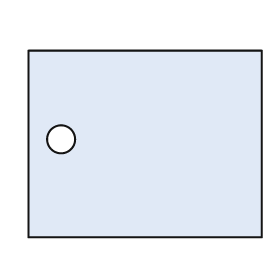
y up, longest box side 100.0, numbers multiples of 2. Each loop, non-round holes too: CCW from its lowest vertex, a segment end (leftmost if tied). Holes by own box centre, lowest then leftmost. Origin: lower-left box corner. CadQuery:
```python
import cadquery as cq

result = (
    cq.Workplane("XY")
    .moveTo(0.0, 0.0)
    .lineTo(100.0, 0.0)
    .lineTo(100.0, 80.0)
    .lineTo(0.0, 80.0)
    .close()
    .moveTo(14.0, 42.0)
    .circle(6.0)
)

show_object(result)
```